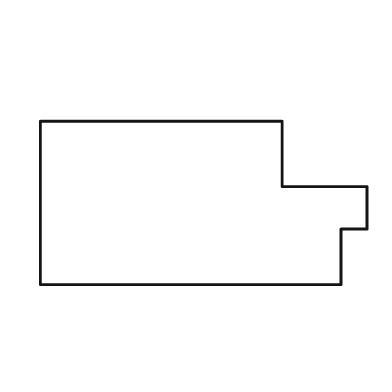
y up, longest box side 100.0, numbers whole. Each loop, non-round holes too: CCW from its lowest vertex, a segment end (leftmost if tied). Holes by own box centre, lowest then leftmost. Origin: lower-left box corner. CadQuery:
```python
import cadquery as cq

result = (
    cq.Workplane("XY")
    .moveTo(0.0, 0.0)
    .lineTo(92.0, 0.0)
    .lineTo(92.0, 17.0)
    .lineTo(100.0, 17.0)
    .lineTo(100.0, 30.0)
    .lineTo(74.0, 30.0)
    .lineTo(74.0, 50.0)
    .lineTo(0.0, 50.0)
    .close()
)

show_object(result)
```